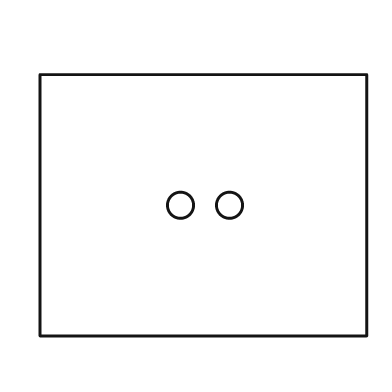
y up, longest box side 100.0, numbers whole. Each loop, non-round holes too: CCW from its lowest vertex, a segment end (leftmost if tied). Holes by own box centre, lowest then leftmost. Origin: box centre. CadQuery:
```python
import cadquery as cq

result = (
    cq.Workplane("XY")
    .moveTo(-50.0, -40.0)
    .lineTo(50.0, -40.0)
    .lineTo(50.0, 40.0)
    .lineTo(-50.0, 40.0)
    .close()
    .moveTo(-7.0, 0.0)
    .circle(4.0)
    .moveTo(8.0, 0.0)
    .circle(4.0)
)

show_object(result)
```